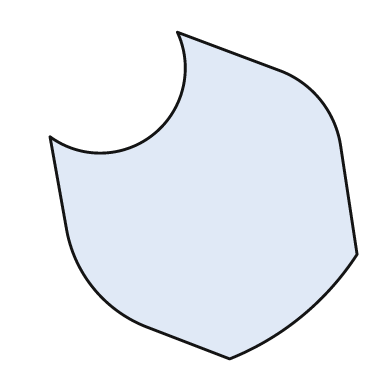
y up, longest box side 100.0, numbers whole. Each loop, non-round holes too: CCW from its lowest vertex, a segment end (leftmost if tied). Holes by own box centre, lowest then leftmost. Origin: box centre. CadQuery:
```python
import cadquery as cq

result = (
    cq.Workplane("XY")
    .moveTo(8.0, -50.0)
    .threePointArc((30.0, -37.0), (47.0, -18.0))
    .lineTo(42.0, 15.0)
    .threePointArc((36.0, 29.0), (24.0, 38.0))
    .lineTo(-8.0, 50.0)
    .threePointArc((-15.0, 19.0), (-47.0, 18.0))
    .lineTo(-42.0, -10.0)
    .threePointArc((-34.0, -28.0), (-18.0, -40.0))
    .close()
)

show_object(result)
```